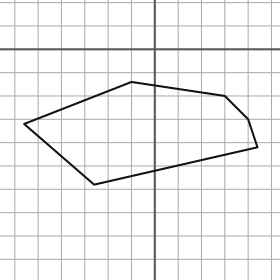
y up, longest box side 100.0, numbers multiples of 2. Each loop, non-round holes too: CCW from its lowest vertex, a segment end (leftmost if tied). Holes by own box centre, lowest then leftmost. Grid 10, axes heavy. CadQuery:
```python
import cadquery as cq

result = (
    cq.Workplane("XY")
    .moveTo(-26.0, -58.0)
    .lineTo(44.0, -42.0)
    .lineTo(40.0, -30.0)
    .lineTo(30.0, -20.0)
    .lineTo(-10.0, -14.0)
    .lineTo(-56.0, -32.0)
    .close()
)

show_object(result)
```